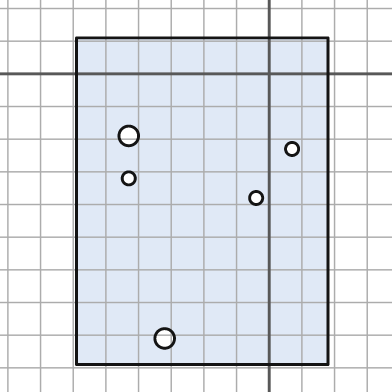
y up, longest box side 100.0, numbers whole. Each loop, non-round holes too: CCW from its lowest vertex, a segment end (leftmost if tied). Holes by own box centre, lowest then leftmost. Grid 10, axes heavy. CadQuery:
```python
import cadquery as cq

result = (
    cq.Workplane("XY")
    .moveTo(-59.0, -89.0)
    .lineTo(18.0, -89.0)
    .lineTo(18.0, 11.0)
    .lineTo(-59.0, 11.0)
    .close()
    .moveTo(-32.0, -81.0)
    .circle(3.0)
    .moveTo(-4.0, -38.0)
    .circle(2.0)
    .moveTo(-43.0, -32.0)
    .circle(2.0)
    .moveTo(7.0, -23.0)
    .circle(2.0)
    .moveTo(-43.0, -19.0)
    .circle(3.0)
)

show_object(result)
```